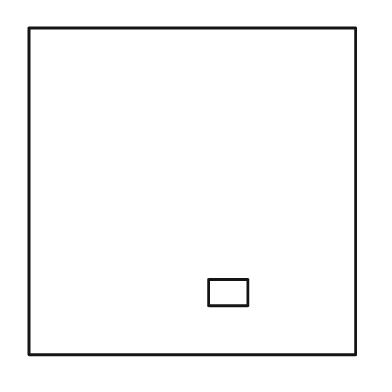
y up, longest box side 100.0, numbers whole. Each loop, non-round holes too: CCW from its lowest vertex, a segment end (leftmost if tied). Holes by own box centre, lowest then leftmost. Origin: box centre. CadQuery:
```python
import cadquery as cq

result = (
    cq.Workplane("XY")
    .moveTo(-50.0, -50.0)
    .lineTo(50.0, -50.0)
    .lineTo(50.0, 50.0)
    .lineTo(-50.0, 50.0)
    .close()
    .moveTo(5.0, -35.0)
    .lineTo(17.0, -35.0)
    .lineTo(17.0, -27.0)
    .lineTo(5.0, -27.0)
    .close()
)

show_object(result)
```